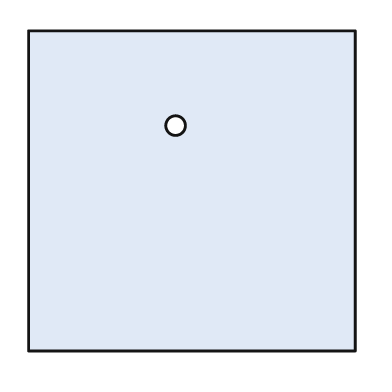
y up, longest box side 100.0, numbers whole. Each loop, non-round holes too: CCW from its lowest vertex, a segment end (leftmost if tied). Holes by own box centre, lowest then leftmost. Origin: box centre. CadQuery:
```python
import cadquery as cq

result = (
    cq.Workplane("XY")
    .moveTo(-50.0, -49.0)
    .lineTo(50.0, -49.0)
    .lineTo(50.0, 49.0)
    .lineTo(-50.0, 49.0)
    .close()
    .moveTo(-5.0, 20.0)
    .circle(3.0)
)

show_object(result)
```